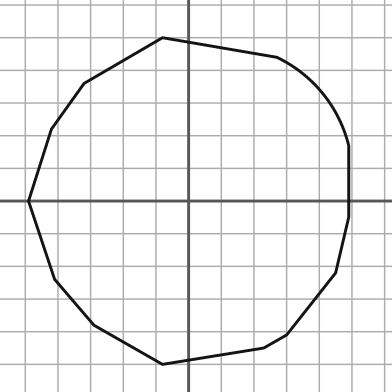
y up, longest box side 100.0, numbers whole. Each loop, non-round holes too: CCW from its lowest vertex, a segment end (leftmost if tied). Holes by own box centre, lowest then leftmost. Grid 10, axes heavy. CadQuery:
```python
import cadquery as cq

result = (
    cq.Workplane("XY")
    .moveTo(-8.0, -50.0)
    .lineTo(23.0, -45.0)
    .lineTo(30.0, -41.0)
    .lineTo(45.0, -22.0)
    .lineTo(49.0, -5.0)
    .lineTo(49.0, 17.0)
    .threePointArc((41.0, 33.0), (27.0, 44.0))
    .lineTo(-8.0, 50.0)
    .lineTo(-32.0, 36.0)
    .lineTo(-42.0, 22.0)
    .lineTo(-49.0, 0.0)
    .lineTo(-41.0, -24.0)
    .lineTo(-29.0, -38.0)
    .close()
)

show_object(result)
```